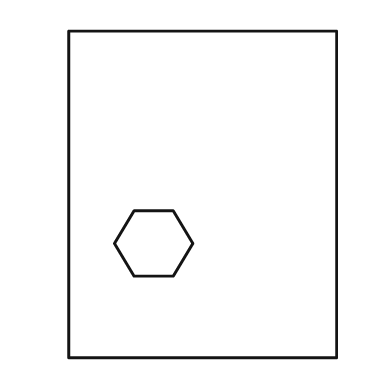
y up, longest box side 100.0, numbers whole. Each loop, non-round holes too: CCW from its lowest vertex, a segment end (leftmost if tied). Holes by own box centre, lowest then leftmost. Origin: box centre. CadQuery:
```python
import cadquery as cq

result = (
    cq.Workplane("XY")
    .moveTo(-41.0, -50.0)
    .lineTo(41.0, -50.0)
    .lineTo(41.0, 50.0)
    .lineTo(-41.0, 50.0)
    .close()
    .moveTo(-21.0, -25.0)
    .lineTo(-9.0, -25.0)
    .lineTo(-3.0, -15.0)
    .lineTo(-9.0, -5.0)
    .lineTo(-21.0, -5.0)
    .lineTo(-27.0, -15.0)
    .close()
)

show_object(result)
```